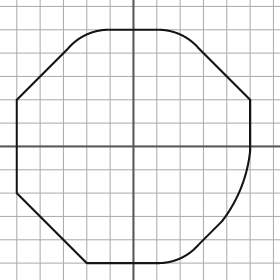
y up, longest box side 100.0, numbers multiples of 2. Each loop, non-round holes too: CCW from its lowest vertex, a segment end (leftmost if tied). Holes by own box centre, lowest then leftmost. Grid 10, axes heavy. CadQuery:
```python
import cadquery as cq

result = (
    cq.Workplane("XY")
    .moveTo(-20.0, -50.0)
    .lineTo(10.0, -50.0)
    .threePointArc((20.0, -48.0), (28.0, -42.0))
    .lineTo(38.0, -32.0)
    .threePointArc((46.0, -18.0), (50.0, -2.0))
    .lineTo(50.0, 20.0)
    .lineTo(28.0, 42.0)
    .threePointArc((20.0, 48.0), (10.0, 50.0))
    .lineTo(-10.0, 50.0)
    .threePointArc((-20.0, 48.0), (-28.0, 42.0))
    .lineTo(-50.0, 20.0)
    .lineTo(-50.0, -20.0)
    .close()
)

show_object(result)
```